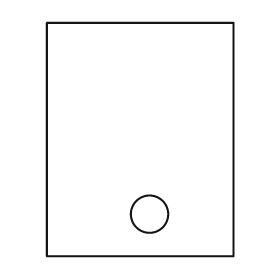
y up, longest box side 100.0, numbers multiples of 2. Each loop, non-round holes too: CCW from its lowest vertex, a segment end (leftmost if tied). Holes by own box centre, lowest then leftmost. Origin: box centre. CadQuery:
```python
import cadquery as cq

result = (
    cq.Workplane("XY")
    .moveTo(-40.0, -50.0)
    .lineTo(40.0, -50.0)
    .lineTo(40.0, 50.0)
    .lineTo(-40.0, 50.0)
    .close()
    .moveTo(4.0, -32.0)
    .circle(8.0)
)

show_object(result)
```